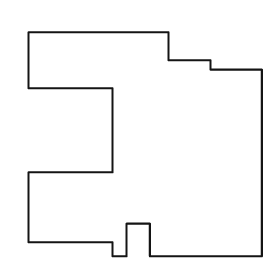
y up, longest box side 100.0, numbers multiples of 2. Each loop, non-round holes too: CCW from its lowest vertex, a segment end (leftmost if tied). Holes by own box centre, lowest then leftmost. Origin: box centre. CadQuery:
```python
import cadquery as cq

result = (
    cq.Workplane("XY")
    .moveTo(-14.0, -48.0)
    .lineTo(-8.0, -48.0)
    .lineTo(-8.0, -34.0)
    .lineTo(2.0, -34.0)
    .lineTo(2.0, -48.0)
    .lineTo(50.0, -48.0)
    .lineTo(50.0, 32.0)
    .lineTo(28.0, 32.0)
    .lineTo(28.0, 36.0)
    .lineTo(10.0, 36.0)
    .lineTo(10.0, 48.0)
    .lineTo(-50.0, 48.0)
    .lineTo(-50.0, 24.0)
    .lineTo(-14.0, 24.0)
    .lineTo(-14.0, -12.0)
    .lineTo(-50.0, -12.0)
    .lineTo(-50.0, -42.0)
    .lineTo(-14.0, -42.0)
    .close()
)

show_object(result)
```